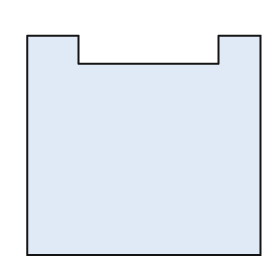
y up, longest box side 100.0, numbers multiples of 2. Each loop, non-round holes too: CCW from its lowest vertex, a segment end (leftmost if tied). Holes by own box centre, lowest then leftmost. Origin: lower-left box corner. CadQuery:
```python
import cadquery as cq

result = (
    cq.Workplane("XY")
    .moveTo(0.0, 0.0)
    .lineTo(100.0, 0.0)
    .lineTo(100.0, 94.0)
    .lineTo(82.0, 94.0)
    .lineTo(82.0, 82.0)
    .lineTo(22.0, 82.0)
    .lineTo(22.0, 94.0)
    .lineTo(0.0, 94.0)
    .close()
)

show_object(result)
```